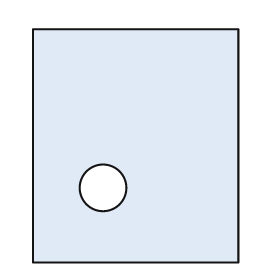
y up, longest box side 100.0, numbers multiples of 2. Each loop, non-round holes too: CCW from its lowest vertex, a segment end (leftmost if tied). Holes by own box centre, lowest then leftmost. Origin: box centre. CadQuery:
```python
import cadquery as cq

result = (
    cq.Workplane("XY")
    .moveTo(-44.0, -50.0)
    .lineTo(44.0, -50.0)
    .lineTo(44.0, 50.0)
    .lineTo(-44.0, 50.0)
    .close()
    .moveTo(-14.0, -18.0)
    .circle(10.0)
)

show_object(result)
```